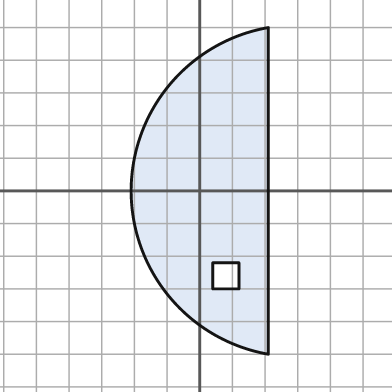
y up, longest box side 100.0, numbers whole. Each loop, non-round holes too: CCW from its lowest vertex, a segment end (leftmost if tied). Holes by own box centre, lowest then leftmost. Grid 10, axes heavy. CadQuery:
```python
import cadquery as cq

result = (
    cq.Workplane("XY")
    .moveTo(21.0, -50.0)
    .lineTo(21.0, 50.0)
    .threePointArc((-21.0, 0.0), (21.0, -50.0))
    .close()
    .moveTo(4.0, -30.0)
    .lineTo(12.0, -30.0)
    .lineTo(12.0, -22.0)
    .lineTo(4.0, -22.0)
    .close()
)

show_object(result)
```